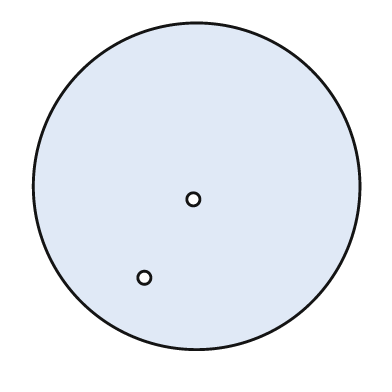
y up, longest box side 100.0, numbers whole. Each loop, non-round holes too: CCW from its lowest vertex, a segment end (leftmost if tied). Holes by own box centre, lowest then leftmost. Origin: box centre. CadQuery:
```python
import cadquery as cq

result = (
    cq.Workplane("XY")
    .moveTo(0.0, 0.0)
    .circle(50.0)
    .moveTo(-16.0, -28.0)
    .circle(2.0)
    .moveTo(-1.0, -4.0)
    .circle(2.0)
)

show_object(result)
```